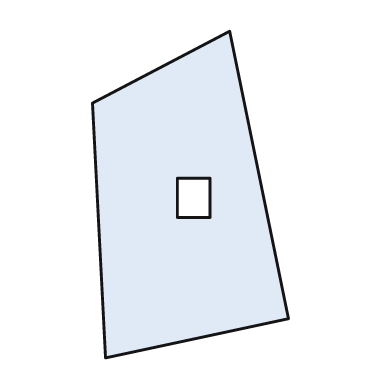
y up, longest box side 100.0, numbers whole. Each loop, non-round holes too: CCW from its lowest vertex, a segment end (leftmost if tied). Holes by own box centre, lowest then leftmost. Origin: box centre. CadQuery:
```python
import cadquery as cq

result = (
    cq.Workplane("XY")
    .moveTo(-26.0, -50.0)
    .lineTo(30.0, -38.0)
    .lineTo(12.0, 50.0)
    .lineTo(-30.0, 28.0)
    .close()
    .moveTo(-4.0, -7.0)
    .lineTo(6.0, -7.0)
    .lineTo(6.0, 5.0)
    .lineTo(-4.0, 5.0)
    .close()
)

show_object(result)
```